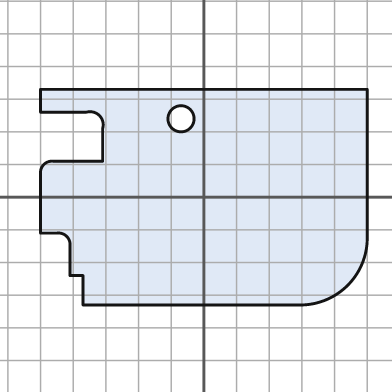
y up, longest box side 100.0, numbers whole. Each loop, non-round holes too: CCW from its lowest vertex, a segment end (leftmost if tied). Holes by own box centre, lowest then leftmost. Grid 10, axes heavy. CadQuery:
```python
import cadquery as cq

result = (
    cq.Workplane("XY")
    .moveTo(-37.0, -33.0)
    .lineTo(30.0, -33.0)
    .threePointArc((44.0, -27.0), (50.0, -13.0))
    .lineTo(50.0, 33.0)
    .lineTo(-50.0, 33.0)
    .lineTo(-50.0, 26.0)
    .lineTo(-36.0, 26.0)
    .threePointArc((-32.0, 25.0), (-31.0, 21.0))
    .lineTo(-31.0, 11.0)
    .lineTo(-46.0, 11.0)
    .threePointArc((-49.0, 10.0), (-50.0, 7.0))
    .lineTo(-50.0, -11.0)
    .lineTo(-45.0, -11.0)
    .threePointArc((-42.0, -12.0), (-41.0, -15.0))
    .lineTo(-41.0, -24.0)
    .lineTo(-37.0, -24.0)
    .close()
    .moveTo(-7.0, 24.0)
    .circle(4.0)
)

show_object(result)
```